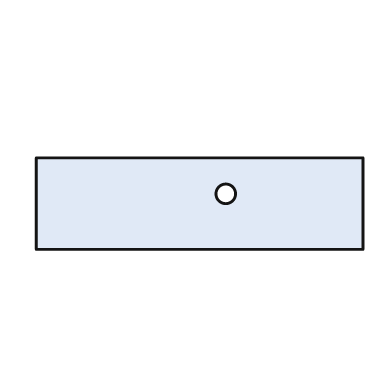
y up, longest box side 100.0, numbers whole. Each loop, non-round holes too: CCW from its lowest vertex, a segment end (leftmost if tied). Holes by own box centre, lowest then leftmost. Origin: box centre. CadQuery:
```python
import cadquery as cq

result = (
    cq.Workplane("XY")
    .moveTo(-50.0, -14.0)
    .lineTo(50.0, -14.0)
    .lineTo(50.0, 14.0)
    .lineTo(-50.0, 14.0)
    .close()
    .moveTo(8.0, 3.0)
    .circle(3.0)
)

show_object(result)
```